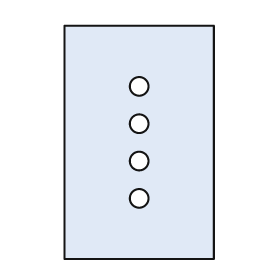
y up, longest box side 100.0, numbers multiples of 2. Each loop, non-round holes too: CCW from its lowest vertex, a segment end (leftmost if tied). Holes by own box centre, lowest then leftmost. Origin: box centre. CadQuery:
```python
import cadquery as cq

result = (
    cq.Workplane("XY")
    .moveTo(-32.0, -50.0)
    .lineTo(32.0, -50.0)
    .lineTo(32.0, 50.0)
    .lineTo(-32.0, 50.0)
    .close()
    .moveTo(0.0, -24.0)
    .circle(4.0)
    .moveTo(0.0, -8.0)
    .circle(4.0)
    .moveTo(0.0, 8.0)
    .circle(4.0)
    .moveTo(0.0, 24.0)
    .circle(4.0)
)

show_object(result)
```